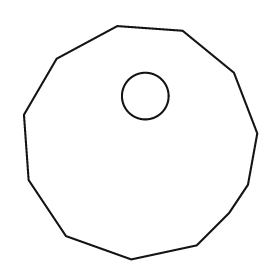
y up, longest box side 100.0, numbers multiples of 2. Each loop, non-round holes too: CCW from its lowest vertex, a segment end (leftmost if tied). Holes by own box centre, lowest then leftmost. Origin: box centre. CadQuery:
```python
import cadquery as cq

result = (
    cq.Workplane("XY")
    .moveTo(-4.0, -50.0)
    .lineTo(24.0, -44.0)
    .lineTo(38.0, -30.0)
    .lineTo(46.0, -18.0)
    .lineTo(50.0, 4.0)
    .lineTo(40.0, 30.0)
    .lineTo(18.0, 48.0)
    .lineTo(-10.0, 50.0)
    .lineTo(-36.0, 36.0)
    .lineTo(-50.0, 12.0)
    .lineTo(-48.0, -16.0)
    .lineTo(-32.0, -40.0)
    .close()
    .moveTo(2.0, 20.0)
    .circle(10.0)
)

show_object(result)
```